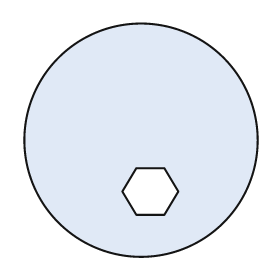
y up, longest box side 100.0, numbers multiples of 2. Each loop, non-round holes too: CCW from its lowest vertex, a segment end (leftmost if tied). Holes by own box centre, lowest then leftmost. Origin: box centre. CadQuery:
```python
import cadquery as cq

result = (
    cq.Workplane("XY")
    .moveTo(0.0, 0.0)
    .circle(50.0)
    .moveTo(-2.0, -32.0)
    .lineTo(10.0, -32.0)
    .lineTo(16.0, -22.0)
    .lineTo(10.0, -12.0)
    .lineTo(-2.0, -12.0)
    .lineTo(-8.0, -22.0)
    .close()
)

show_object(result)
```